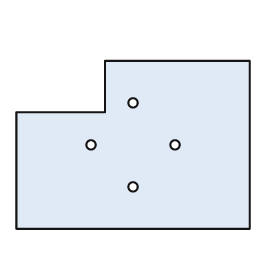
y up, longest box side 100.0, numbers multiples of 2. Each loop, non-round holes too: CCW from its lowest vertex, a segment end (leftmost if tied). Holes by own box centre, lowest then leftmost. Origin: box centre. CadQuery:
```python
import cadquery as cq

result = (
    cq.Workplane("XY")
    .moveTo(-50.0, -36.0)
    .lineTo(50.0, -36.0)
    .lineTo(50.0, 36.0)
    .lineTo(-12.0, 36.0)
    .lineTo(-12.0, 14.0)
    .lineTo(-50.0, 14.0)
    .close()
    .moveTo(0.0, -18.0)
    .circle(2.0)
    .moveTo(-18.0, 0.0)
    .circle(2.0)
    .moveTo(18.0, 0.0)
    .circle(2.0)
    .moveTo(0.0, 18.0)
    .circle(2.0)
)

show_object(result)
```